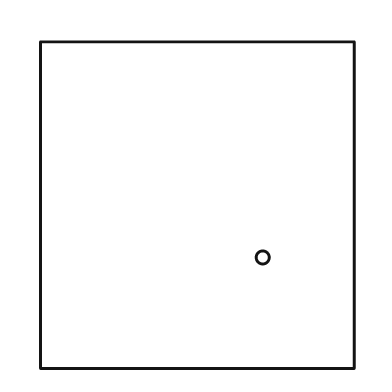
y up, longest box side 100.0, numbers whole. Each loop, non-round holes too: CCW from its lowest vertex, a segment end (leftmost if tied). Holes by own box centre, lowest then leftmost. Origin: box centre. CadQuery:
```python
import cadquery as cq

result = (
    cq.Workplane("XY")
    .moveTo(-48.0, -50.0)
    .lineTo(48.0, -50.0)
    .lineTo(48.0, 50.0)
    .lineTo(-48.0, 50.0)
    .close()
    .moveTo(20.0, -16.0)
    .circle(2.0)
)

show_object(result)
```